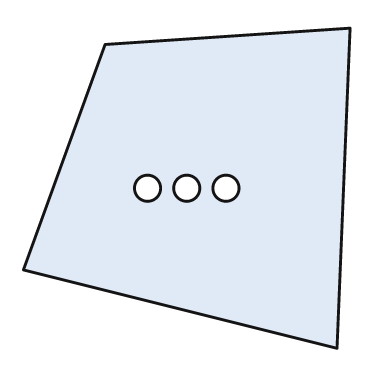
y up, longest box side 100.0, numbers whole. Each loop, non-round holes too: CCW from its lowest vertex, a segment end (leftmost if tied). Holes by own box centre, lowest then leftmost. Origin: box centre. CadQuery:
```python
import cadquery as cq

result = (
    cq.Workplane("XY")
    .moveTo(46.0, -49.0)
    .lineTo(50.0, 49.0)
    .lineTo(-25.0, 44.0)
    .lineTo(-50.0, -25.0)
    .close()
    .moveTo(-12.0, 0.0)
    .circle(4.0)
    .moveTo(0.0, 0.0)
    .circle(4.0)
    .moveTo(12.0, 0.0)
    .circle(4.0)
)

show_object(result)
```